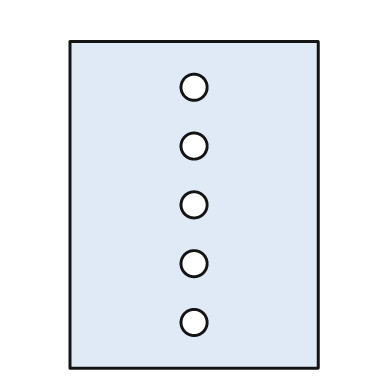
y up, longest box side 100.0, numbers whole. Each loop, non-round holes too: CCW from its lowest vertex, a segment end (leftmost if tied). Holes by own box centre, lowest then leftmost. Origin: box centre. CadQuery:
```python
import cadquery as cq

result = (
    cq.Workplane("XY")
    .moveTo(-38.0, -50.0)
    .lineTo(38.0, -50.0)
    .lineTo(38.0, 50.0)
    .lineTo(-38.0, 50.0)
    .close()
    .moveTo(0.0, -36.0)
    .circle(4.0)
    .moveTo(0.0, -18.0)
    .circle(4.0)
    .moveTo(0.0, 0.0)
    .circle(4.0)
    .moveTo(0.0, 18.0)
    .circle(4.0)
    .moveTo(0.0, 36.0)
    .circle(4.0)
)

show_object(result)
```